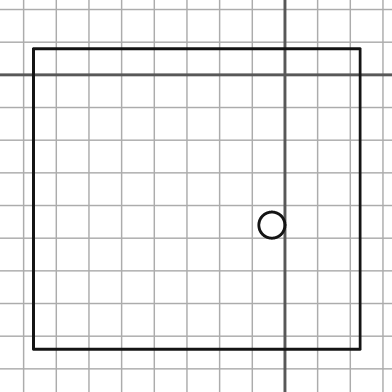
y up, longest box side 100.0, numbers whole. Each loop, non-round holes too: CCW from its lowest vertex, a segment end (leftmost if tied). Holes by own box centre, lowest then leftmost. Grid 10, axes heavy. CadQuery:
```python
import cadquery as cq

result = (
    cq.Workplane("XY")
    .moveTo(-77.0, -84.0)
    .lineTo(23.0, -84.0)
    .lineTo(23.0, 8.0)
    .lineTo(-77.0, 8.0)
    .close()
    .moveTo(-4.0, -46.0)
    .circle(4.0)
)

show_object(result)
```